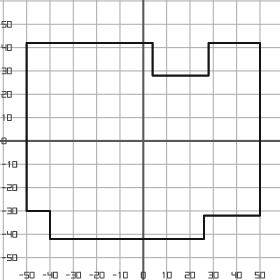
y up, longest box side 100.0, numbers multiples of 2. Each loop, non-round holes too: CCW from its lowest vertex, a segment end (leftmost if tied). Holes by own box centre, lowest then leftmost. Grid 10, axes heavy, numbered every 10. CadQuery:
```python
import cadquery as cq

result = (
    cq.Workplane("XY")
    .moveTo(-40.0, -42.0)
    .lineTo(26.0, -42.0)
    .lineTo(26.0, -32.0)
    .lineTo(50.0, -32.0)
    .lineTo(50.0, 42.0)
    .lineTo(28.0, 42.0)
    .lineTo(28.0, 28.0)
    .lineTo(4.0, 28.0)
    .lineTo(4.0, 42.0)
    .lineTo(-50.0, 42.0)
    .lineTo(-50.0, -30.0)
    .lineTo(-40.0, -30.0)
    .close()
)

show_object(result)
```